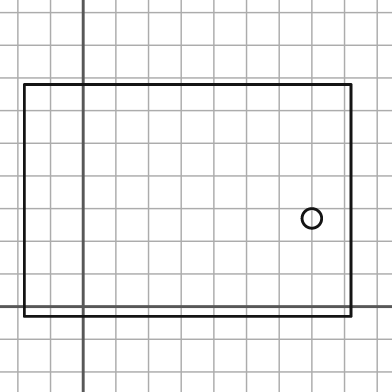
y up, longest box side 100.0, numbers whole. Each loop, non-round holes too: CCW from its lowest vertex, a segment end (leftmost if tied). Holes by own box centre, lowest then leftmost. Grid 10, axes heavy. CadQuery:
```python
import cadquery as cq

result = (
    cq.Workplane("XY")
    .moveTo(-18.0, -3.0)
    .lineTo(82.0, -3.0)
    .lineTo(82.0, 68.0)
    .lineTo(-18.0, 68.0)
    .close()
    .moveTo(70.0, 27.0)
    .circle(3.0)
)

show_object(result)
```